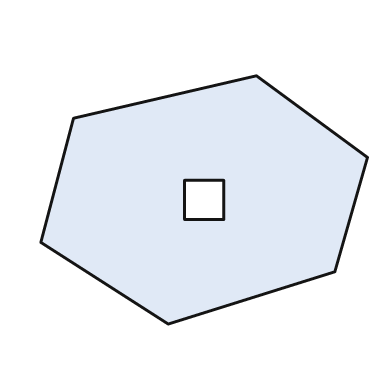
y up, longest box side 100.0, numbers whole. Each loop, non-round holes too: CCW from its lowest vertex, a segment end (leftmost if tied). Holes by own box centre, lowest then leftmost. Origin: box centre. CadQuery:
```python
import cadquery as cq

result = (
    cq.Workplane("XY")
    .moveTo(-11.0, -38.0)
    .lineTo(40.0, -22.0)
    .lineTo(50.0, 13.0)
    .lineTo(16.0, 38.0)
    .lineTo(-40.0, 25.0)
    .lineTo(-50.0, -13.0)
    .close()
    .moveTo(-6.0, -6.0)
    .lineTo(6.0, -6.0)
    .lineTo(6.0, 6.0)
    .lineTo(-6.0, 6.0)
    .close()
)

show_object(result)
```